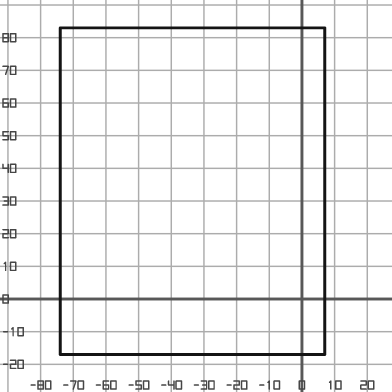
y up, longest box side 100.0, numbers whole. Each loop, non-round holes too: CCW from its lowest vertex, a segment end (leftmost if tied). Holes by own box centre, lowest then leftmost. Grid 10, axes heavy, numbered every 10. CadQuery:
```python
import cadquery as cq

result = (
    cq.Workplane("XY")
    .moveTo(-74.0, -17.0)
    .lineTo(7.0, -17.0)
    .lineTo(7.0, 83.0)
    .lineTo(-74.0, 83.0)
    .close()
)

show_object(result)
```